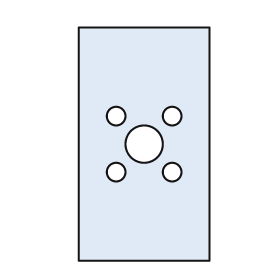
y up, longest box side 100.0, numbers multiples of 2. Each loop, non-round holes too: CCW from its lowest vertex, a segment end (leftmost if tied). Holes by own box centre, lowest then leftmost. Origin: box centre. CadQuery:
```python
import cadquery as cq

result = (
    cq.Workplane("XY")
    .moveTo(-28.0, -50.0)
    .lineTo(28.0, -50.0)
    .lineTo(28.0, 50.0)
    .lineTo(-28.0, 50.0)
    .close()
    .moveTo(-12.0, -12.0)
    .circle(4.0)
    .moveTo(12.0, -12.0)
    .circle(4.0)
    .moveTo(0.0, 0.0)
    .circle(8.0)
    .moveTo(-12.0, 12.0)
    .circle(4.0)
    .moveTo(12.0, 12.0)
    .circle(4.0)
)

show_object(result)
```